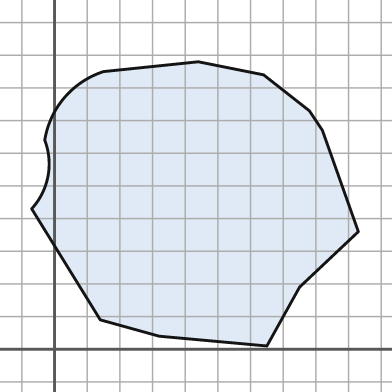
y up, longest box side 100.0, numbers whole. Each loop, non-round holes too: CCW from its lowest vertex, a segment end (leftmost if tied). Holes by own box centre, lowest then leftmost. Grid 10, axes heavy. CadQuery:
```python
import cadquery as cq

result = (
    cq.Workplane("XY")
    .moveTo(65.0, 1.0)
    .lineTo(75.0, 19.0)
    .lineTo(93.0, 36.0)
    .lineTo(82.0, 67.0)
    .lineTo(78.0, 73.0)
    .lineTo(64.0, 84.0)
    .lineTo(44.0, 88.0)
    .lineTo(15.0, 85.0)
    .threePointArc((3.0, 77.0), (-3.0, 64.0))
    .threePointArc((-2.0, 53.0), (-7.0, 43.0))
    .lineTo(14.0, 9.0)
    .lineTo(32.0, 4.0)
    .close()
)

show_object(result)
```